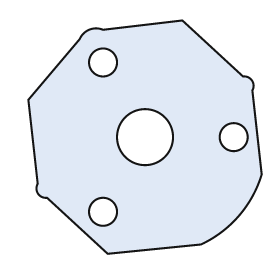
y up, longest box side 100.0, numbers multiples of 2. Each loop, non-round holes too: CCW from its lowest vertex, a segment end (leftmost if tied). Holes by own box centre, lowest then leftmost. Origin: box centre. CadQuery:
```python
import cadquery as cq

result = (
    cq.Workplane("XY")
    .moveTo(-16.0, -50.0)
    .lineTo(24.0, -46.0)
    .threePointArc((40.0, -34.0), (50.0, -16.0))
    .lineTo(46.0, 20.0)
    .threePointArc((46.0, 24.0), (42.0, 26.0))
    .lineTo(16.0, 50.0)
    .lineTo(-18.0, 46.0)
    .threePointArc((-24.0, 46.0), (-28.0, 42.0))
    .lineTo(-50.0, 16.0)
    .lineTo(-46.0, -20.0)
    .threePointArc((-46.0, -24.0), (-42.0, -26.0))
    .close()
    .moveTo(-18.0, -32.0)
    .circle(6.0)
    .moveTo(0.0, 0.0)
    .circle(12.0)
    .moveTo(38.0, 0.0)
    .circle(6.0)
    .moveTo(-18.0, 32.0)
    .circle(6.0)
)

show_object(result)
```